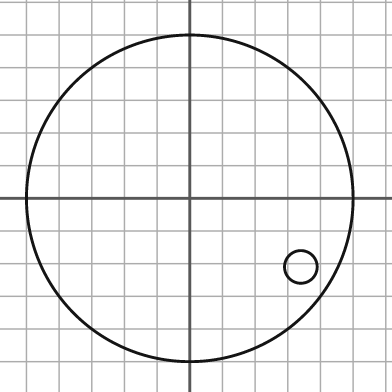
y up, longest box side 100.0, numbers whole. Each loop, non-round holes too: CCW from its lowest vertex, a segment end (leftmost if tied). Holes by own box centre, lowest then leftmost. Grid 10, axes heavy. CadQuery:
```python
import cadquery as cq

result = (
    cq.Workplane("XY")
    .moveTo(0.0, 0.0)
    .circle(50.0)
    .moveTo(34.0, -21.0)
    .circle(5.0)
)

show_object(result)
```